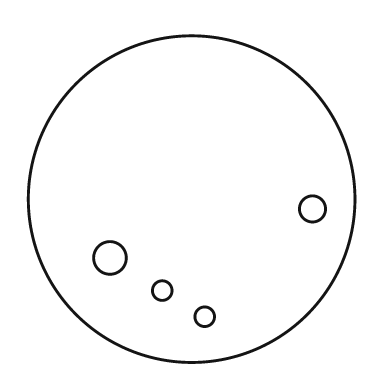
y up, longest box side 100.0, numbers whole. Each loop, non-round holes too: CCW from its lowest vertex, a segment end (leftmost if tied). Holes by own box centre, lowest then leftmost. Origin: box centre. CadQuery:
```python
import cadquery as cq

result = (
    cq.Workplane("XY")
    .moveTo(0.0, 0.0)
    .circle(50.0)
    .moveTo(4.0, -36.0)
    .circle(3.0)
    .moveTo(-9.0, -28.0)
    .circle(3.0)
    .moveTo(-25.0, -18.0)
    .circle(5.0)
    .moveTo(37.0, -3.0)
    .circle(4.0)
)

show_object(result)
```